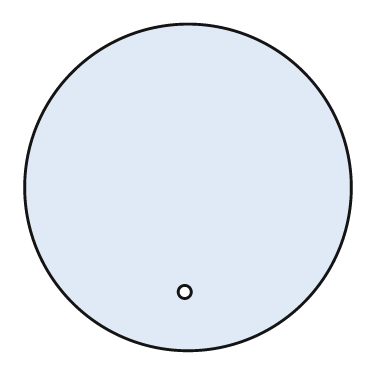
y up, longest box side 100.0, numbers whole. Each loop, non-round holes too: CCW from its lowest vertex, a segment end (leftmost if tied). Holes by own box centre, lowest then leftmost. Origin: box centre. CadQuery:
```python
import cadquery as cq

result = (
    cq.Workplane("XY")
    .moveTo(0.0, 0.0)
    .circle(50.0)
    .moveTo(-1.0, -32.0)
    .circle(2.0)
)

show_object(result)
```